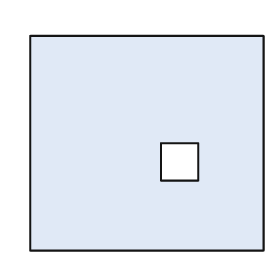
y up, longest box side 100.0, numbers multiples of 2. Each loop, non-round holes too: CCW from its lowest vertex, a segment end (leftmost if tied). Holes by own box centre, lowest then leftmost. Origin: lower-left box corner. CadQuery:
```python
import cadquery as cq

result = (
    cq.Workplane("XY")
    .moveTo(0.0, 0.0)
    .lineTo(100.0, 0.0)
    .lineTo(100.0, 92.0)
    .lineTo(0.0, 92.0)
    .close()
    .moveTo(56.0, 30.0)
    .lineTo(72.0, 30.0)
    .lineTo(72.0, 46.0)
    .lineTo(56.0, 46.0)
    .close()
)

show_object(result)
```